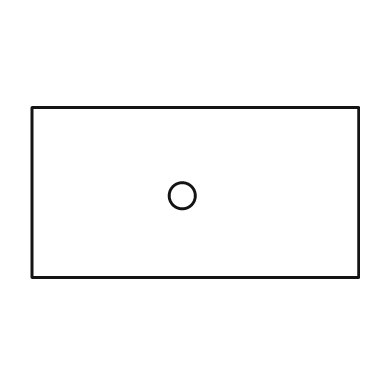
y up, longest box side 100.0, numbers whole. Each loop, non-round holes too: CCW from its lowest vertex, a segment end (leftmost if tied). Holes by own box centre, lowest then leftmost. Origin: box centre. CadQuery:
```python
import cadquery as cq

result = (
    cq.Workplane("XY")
    .moveTo(-50.0, -26.0)
    .lineTo(50.0, -26.0)
    .lineTo(50.0, 26.0)
    .lineTo(-50.0, 26.0)
    .close()
    .moveTo(-4.0, -1.0)
    .circle(4.0)
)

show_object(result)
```